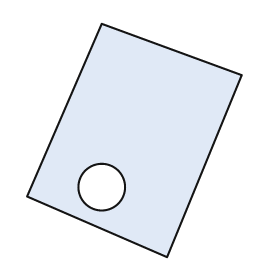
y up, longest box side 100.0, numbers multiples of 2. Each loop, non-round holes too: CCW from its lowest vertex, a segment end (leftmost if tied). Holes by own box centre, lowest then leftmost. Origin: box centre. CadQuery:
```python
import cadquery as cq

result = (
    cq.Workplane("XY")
    .moveTo(14.0, -50.0)
    .lineTo(46.0, 28.0)
    .lineTo(-14.0, 50.0)
    .lineTo(-46.0, -24.0)
    .close()
    .moveTo(-14.0, -20.0)
    .circle(10.0)
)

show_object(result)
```